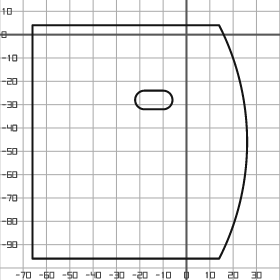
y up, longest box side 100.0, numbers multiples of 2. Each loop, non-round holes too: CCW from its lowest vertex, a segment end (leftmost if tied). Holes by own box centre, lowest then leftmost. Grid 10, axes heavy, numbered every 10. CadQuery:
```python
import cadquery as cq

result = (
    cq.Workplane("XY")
    .moveTo(-66.0, -96.0)
    .lineTo(14.0, -96.0)
    .threePointArc((26.0, -46.0), (14.0, 4.0))
    .lineTo(-66.0, 4.0)
    .close()
    .moveTo(-18.0, -32.0)
    .lineTo(-10.0, -32.0)
    .threePointArc((-6.0, -28.0), (-10.0, -24.0))
    .lineTo(-18.0, -24.0)
    .threePointArc((-22.0, -28.0), (-18.0, -32.0))
    .close()
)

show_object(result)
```